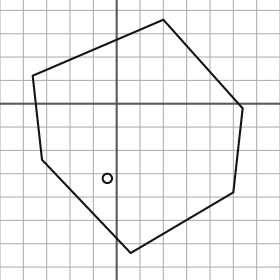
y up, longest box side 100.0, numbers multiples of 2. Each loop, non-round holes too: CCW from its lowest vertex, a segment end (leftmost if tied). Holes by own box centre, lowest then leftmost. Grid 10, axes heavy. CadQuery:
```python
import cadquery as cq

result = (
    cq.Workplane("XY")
    .moveTo(6.0, -64.0)
    .lineTo(50.0, -38.0)
    .lineTo(54.0, -2.0)
    .lineTo(20.0, 36.0)
    .lineTo(-36.0, 12.0)
    .lineTo(-32.0, -24.0)
    .close()
    .moveTo(-4.0, -32.0)
    .circle(2.0)
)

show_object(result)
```